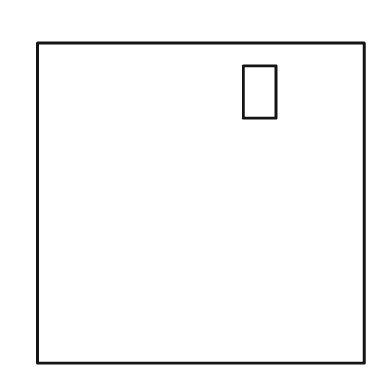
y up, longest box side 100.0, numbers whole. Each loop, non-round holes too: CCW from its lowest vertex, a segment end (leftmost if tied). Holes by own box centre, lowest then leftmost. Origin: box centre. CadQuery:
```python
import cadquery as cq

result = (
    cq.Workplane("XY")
    .moveTo(-50.0, -49.0)
    .lineTo(50.0, -49.0)
    .lineTo(50.0, 49.0)
    .lineTo(-50.0, 49.0)
    .close()
    .moveTo(13.0, 26.0)
    .lineTo(23.0, 26.0)
    .lineTo(23.0, 42.0)
    .lineTo(13.0, 42.0)
    .close()
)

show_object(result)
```